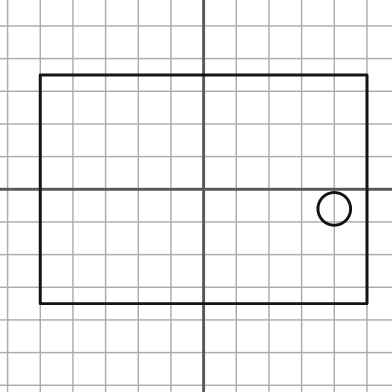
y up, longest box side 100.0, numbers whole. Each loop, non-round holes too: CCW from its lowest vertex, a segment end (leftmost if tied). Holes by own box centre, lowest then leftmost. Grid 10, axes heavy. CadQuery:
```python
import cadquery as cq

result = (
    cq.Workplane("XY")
    .moveTo(-50.0, -35.0)
    .lineTo(50.0, -35.0)
    .lineTo(50.0, 35.0)
    .lineTo(-50.0, 35.0)
    .close()
    .moveTo(40.0, -6.0)
    .circle(5.0)
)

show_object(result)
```